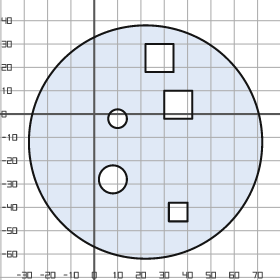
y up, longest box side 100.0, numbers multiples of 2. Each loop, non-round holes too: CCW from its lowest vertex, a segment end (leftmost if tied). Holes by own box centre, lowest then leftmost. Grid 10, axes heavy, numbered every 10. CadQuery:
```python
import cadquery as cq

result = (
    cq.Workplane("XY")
    .moveTo(22.0, -12.0)
    .circle(50.0)
    .moveTo(32.0, -46.0)
    .lineTo(40.0, -46.0)
    .lineTo(40.0, -38.0)
    .lineTo(32.0, -38.0)
    .close()
    .moveTo(8.0, -28.0)
    .circle(6.0)
    .moveTo(10.0, -2.0)
    .circle(4.0)
    .moveTo(30.0, -2.0)
    .lineTo(42.0, -2.0)
    .lineTo(42.0, 10.0)
    .lineTo(30.0, 10.0)
    .close()
    .moveTo(22.0, 18.0)
    .lineTo(34.0, 18.0)
    .lineTo(34.0, 30.0)
    .lineTo(22.0, 30.0)
    .close()
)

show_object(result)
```